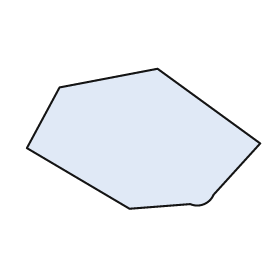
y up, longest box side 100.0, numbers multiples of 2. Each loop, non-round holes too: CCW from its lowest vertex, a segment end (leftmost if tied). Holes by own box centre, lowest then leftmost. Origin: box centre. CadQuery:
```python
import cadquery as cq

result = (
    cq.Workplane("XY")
    .moveTo(-6.0, -30.0)
    .lineTo(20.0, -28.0)
    .threePointArc((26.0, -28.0), (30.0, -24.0))
    .lineTo(50.0, -2.0)
    .lineTo(6.0, 30.0)
    .lineTo(-36.0, 22.0)
    .lineTo(-50.0, -4.0)
    .close()
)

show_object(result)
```